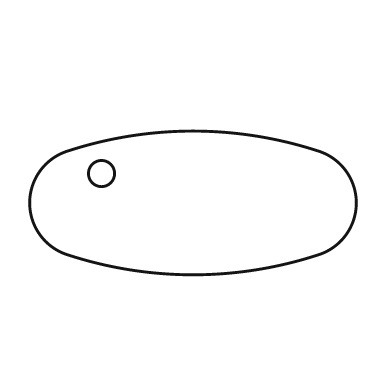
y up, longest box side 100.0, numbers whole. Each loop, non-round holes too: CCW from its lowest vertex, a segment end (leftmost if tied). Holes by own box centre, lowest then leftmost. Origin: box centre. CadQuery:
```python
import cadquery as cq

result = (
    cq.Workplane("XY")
    .moveTo(-38.0, -16.0)
    .threePointArc((0.0, -22.0), (38.0, -16.0))
    .threePointArc((50.0, 0.0), (38.0, 16.0))
    .threePointArc((0.0, 22.0), (-38.0, 16.0))
    .threePointArc((-50.0, 0.0), (-38.0, -16.0))
    .close()
    .moveTo(-28.0, 9.0)
    .circle(4.0)
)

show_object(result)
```